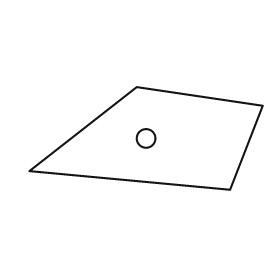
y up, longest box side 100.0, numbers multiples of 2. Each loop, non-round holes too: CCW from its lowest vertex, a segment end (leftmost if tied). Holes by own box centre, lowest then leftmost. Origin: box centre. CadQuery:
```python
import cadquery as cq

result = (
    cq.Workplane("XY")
    .moveTo(36.0, -22.0)
    .lineTo(50.0, 14.0)
    .lineTo(-4.0, 22.0)
    .lineTo(-50.0, -14.0)
    .close()
    .moveTo(0.0, 0.0)
    .circle(4.0)
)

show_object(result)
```